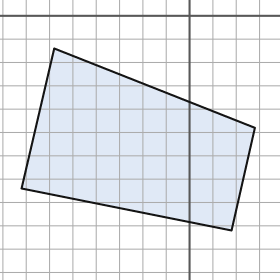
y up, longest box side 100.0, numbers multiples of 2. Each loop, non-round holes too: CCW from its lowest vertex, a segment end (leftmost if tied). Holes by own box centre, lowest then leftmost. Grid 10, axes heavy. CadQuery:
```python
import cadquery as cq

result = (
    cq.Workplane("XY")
    .moveTo(18.0, -92.0)
    .lineTo(28.0, -48.0)
    .lineTo(-58.0, -14.0)
    .lineTo(-72.0, -74.0)
    .close()
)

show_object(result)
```